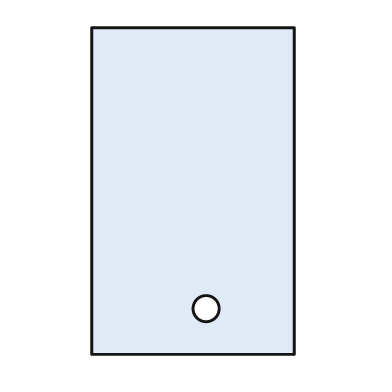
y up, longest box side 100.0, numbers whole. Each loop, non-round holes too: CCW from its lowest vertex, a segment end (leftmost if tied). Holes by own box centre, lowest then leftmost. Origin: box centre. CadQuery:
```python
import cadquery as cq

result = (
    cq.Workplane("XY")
    .moveTo(-31.0, -50.0)
    .lineTo(31.0, -50.0)
    .lineTo(31.0, 50.0)
    .lineTo(-31.0, 50.0)
    .close()
    .moveTo(4.0, -36.0)
    .circle(4.0)
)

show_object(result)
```